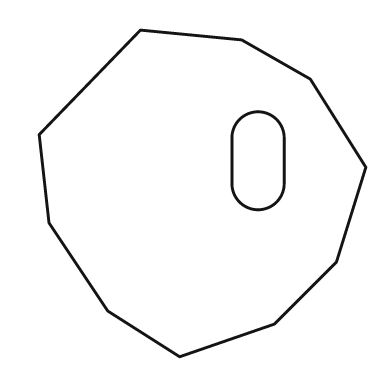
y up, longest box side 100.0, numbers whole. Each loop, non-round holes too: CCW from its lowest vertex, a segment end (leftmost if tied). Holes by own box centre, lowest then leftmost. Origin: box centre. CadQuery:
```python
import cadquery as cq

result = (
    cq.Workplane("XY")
    .moveTo(-7.0, -50.0)
    .lineTo(22.0, -40.0)
    .lineTo(41.0, -21.0)
    .lineTo(50.0, 8.0)
    .lineTo(33.0, 35.0)
    .lineTo(12.0, 47.0)
    .lineTo(-19.0, 50.0)
    .lineTo(-50.0, 18.0)
    .lineTo(-47.0, -9.0)
    .lineTo(-29.0, -36.0)
    .close()
    .moveTo(9.0, 3.0)
    .threePointArc((17.0, -5.0), (25.0, 3.0))
    .lineTo(25.0, 17.0)
    .threePointArc((17.0, 25.0), (9.0, 17.0))
    .close()
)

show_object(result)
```